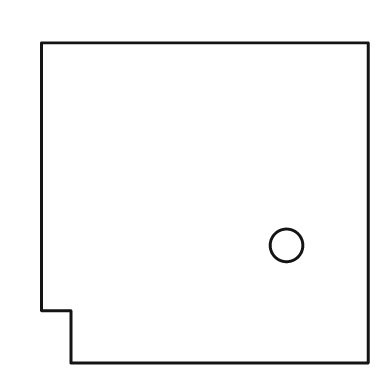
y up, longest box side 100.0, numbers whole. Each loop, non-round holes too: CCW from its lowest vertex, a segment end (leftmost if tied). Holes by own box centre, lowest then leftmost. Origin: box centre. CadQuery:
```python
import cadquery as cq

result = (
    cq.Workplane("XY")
    .moveTo(-41.0, -49.0)
    .lineTo(50.0, -49.0)
    .lineTo(50.0, 49.0)
    .lineTo(-50.0, 49.0)
    .lineTo(-50.0, -33.0)
    .lineTo(-41.0, -33.0)
    .close()
    .moveTo(25.0, -13.0)
    .circle(5.0)
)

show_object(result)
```